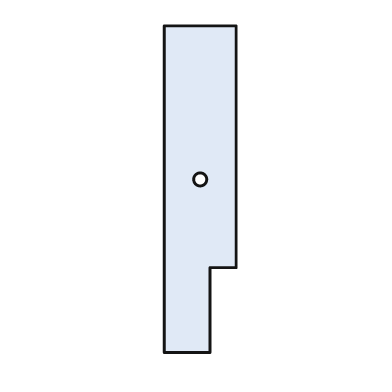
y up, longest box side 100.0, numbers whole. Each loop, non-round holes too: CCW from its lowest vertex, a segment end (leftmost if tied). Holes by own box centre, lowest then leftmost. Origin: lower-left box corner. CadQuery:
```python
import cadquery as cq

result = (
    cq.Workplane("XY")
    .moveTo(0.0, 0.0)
    .lineTo(14.0, 0.0)
    .lineTo(14.0, 26.0)
    .lineTo(22.0, 26.0)
    .lineTo(22.0, 100.0)
    .lineTo(0.0, 100.0)
    .close()
    .moveTo(11.0, 53.0)
    .circle(2.0)
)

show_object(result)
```